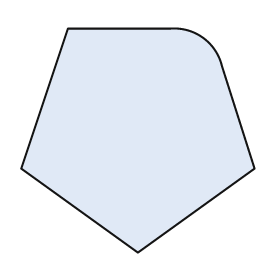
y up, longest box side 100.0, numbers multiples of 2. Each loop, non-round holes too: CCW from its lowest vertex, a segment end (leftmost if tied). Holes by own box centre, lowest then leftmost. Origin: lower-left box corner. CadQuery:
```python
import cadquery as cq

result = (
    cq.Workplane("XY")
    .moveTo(50.0, 0.0)
    .lineTo(100.0, 36.0)
    .lineTo(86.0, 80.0)
    .threePointArc((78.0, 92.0), (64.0, 96.0))
    .lineTo(20.0, 96.0)
    .lineTo(0.0, 36.0)
    .close()
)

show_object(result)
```